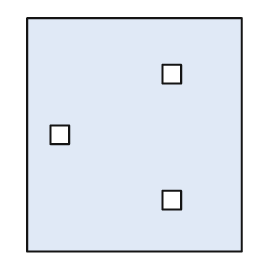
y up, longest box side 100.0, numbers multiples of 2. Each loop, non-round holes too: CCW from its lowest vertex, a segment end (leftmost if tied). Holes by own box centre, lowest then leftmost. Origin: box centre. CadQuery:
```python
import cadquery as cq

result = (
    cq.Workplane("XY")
    .moveTo(-46.0, -50.0)
    .lineTo(46.0, -50.0)
    .lineTo(46.0, 50.0)
    .lineTo(-46.0, 50.0)
    .close()
    .moveTo(12.0, -32.0)
    .lineTo(20.0, -32.0)
    .lineTo(20.0, -24.0)
    .lineTo(12.0, -24.0)
    .close()
    .moveTo(-36.0, -4.0)
    .lineTo(-28.0, -4.0)
    .lineTo(-28.0, 4.0)
    .lineTo(-36.0, 4.0)
    .close()
    .moveTo(12.0, 22.0)
    .lineTo(20.0, 22.0)
    .lineTo(20.0, 30.0)
    .lineTo(12.0, 30.0)
    .close()
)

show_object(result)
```